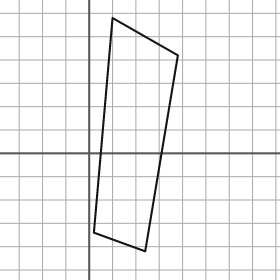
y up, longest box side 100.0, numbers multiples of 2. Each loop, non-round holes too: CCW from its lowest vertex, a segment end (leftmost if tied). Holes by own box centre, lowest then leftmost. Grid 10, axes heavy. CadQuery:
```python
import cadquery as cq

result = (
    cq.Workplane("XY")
    .moveTo(24.0, -42.0)
    .lineTo(38.0, 42.0)
    .lineTo(10.0, 58.0)
    .lineTo(2.0, -34.0)
    .close()
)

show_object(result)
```